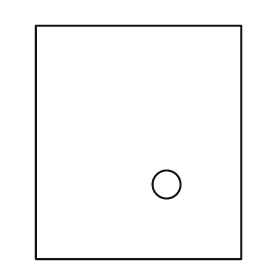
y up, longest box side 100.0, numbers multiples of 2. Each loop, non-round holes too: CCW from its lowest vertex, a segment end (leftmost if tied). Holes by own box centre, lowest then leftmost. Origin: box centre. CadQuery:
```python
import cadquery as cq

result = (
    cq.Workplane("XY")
    .moveTo(-44.0, -50.0)
    .lineTo(44.0, -50.0)
    .lineTo(44.0, 50.0)
    .lineTo(-44.0, 50.0)
    .close()
    .moveTo(12.0, -18.0)
    .circle(6.0)
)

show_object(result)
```